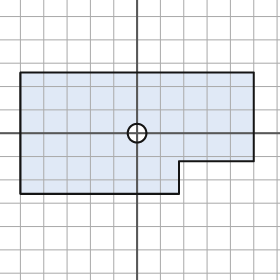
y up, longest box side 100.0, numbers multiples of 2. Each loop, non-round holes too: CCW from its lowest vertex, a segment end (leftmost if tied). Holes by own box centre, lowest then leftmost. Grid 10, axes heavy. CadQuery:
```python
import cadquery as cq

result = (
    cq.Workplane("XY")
    .moveTo(-50.0, -26.0)
    .lineTo(18.0, -26.0)
    .lineTo(18.0, -12.0)
    .lineTo(50.0, -12.0)
    .lineTo(50.0, 26.0)
    .lineTo(-50.0, 26.0)
    .close()
    .moveTo(0.0, 0.0)
    .circle(4.0)
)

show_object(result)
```